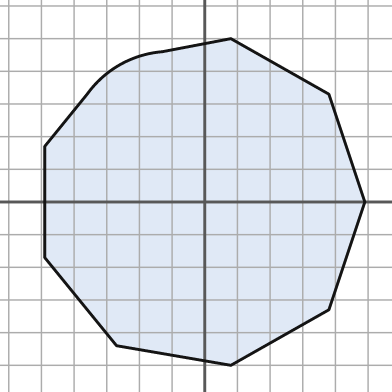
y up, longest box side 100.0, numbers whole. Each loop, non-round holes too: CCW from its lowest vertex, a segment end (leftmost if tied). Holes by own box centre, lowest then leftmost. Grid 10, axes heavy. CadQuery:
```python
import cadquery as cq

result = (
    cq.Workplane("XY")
    .moveTo(8.0, -50.0)
    .lineTo(38.0, -33.0)
    .lineTo(49.0, 0.0)
    .lineTo(38.0, 33.0)
    .lineTo(8.0, 50.0)
    .lineTo(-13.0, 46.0)
    .threePointArc((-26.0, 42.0), (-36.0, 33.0))
    .lineTo(-49.0, 17.0)
    .lineTo(-49.0, -17.0)
    .lineTo(-27.0, -44.0)
    .close()
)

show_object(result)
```